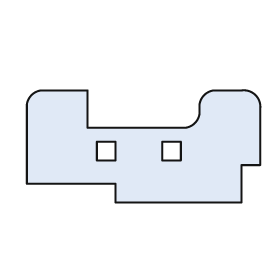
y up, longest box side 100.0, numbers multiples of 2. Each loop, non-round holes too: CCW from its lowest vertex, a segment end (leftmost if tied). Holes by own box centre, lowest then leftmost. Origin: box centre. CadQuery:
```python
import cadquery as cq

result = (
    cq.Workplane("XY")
    .moveTo(-12.0, -24.0)
    .lineTo(42.0, -24.0)
    .lineTo(42.0, -8.0)
    .lineTo(50.0, -8.0)
    .lineTo(50.0, 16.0)
    .threePointArc((48.0, 22.0), (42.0, 24.0))
    .lineTo(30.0, 24.0)
    .threePointArc((26.0, 22.0), (24.0, 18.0))
    .lineTo(24.0, 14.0)
    .threePointArc((22.0, 10.0), (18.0, 8.0))
    .lineTo(-24.0, 8.0)
    .lineTo(-24.0, 24.0)
    .lineTo(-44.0, 24.0)
    .threePointArc((-48.0, 22.0), (-50.0, 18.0))
    .lineTo(-50.0, -16.0)
    .lineTo(-12.0, -16.0)
    .close()
    .moveTo(-20.0, -6.0)
    .lineTo(-12.0, -6.0)
    .lineTo(-12.0, 2.0)
    .lineTo(-20.0, 2.0)
    .close()
    .moveTo(8.0, -6.0)
    .lineTo(16.0, -6.0)
    .lineTo(16.0, 2.0)
    .lineTo(8.0, 2.0)
    .close()
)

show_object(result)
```